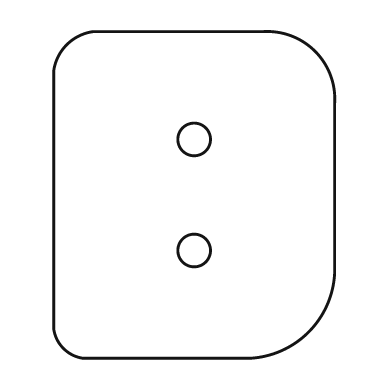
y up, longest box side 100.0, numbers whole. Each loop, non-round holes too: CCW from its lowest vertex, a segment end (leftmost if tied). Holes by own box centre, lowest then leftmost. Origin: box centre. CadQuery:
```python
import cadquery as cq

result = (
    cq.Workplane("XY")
    .moveTo(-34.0, -50.0)
    .lineTo(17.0, -50.0)
    .threePointArc((35.0, -42.0), (43.0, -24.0))
    .lineTo(43.0, 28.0)
    .threePointArc((37.0, 44.0), (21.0, 50.0))
    .lineTo(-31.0, 50.0)
    .threePointArc((-39.0, 46.0), (-43.0, 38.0))
    .lineTo(-43.0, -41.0)
    .threePointArc((-40.0, -47.0), (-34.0, -50.0))
    .close()
    .moveTo(0.0, -17.0)
    .circle(5.0)
    .moveTo(0.0, 17.0)
    .circle(5.0)
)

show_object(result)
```